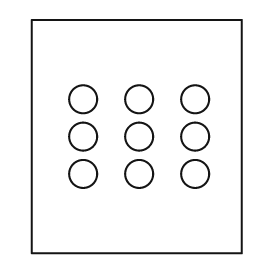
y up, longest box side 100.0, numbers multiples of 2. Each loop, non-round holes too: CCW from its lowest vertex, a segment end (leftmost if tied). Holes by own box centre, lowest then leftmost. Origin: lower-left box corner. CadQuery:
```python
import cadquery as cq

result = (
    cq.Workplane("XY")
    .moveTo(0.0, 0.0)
    .lineTo(90.0, 0.0)
    .lineTo(90.0, 100.0)
    .lineTo(0.0, 100.0)
    .close()
    .moveTo(22.0, 34.0)
    .circle(6.0)
    .moveTo(46.0, 34.0)
    .circle(6.0)
    .moveTo(70.0, 34.0)
    .circle(6.0)
    .moveTo(22.0, 50.0)
    .circle(6.0)
    .moveTo(46.0, 50.0)
    .circle(6.0)
    .moveTo(70.0, 50.0)
    .circle(6.0)
    .moveTo(22.0, 66.0)
    .circle(6.0)
    .moveTo(46.0, 66.0)
    .circle(6.0)
    .moveTo(70.0, 66.0)
    .circle(6.0)
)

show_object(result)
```